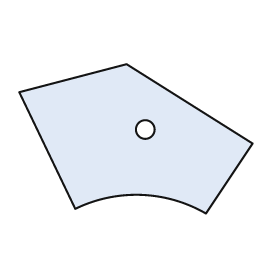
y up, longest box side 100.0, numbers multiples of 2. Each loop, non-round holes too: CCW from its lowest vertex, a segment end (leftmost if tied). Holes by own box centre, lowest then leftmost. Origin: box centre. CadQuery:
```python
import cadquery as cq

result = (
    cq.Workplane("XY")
    .moveTo(30.0, -32.0)
    .lineTo(50.0, -2.0)
    .lineTo(-4.0, 32.0)
    .lineTo(-50.0, 20.0)
    .lineTo(-26.0, -30.0)
    .threePointArc((2.0, -24.0), (30.0, -32.0))
    .close()
    .moveTo(4.0, 4.0)
    .circle(4.0)
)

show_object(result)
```